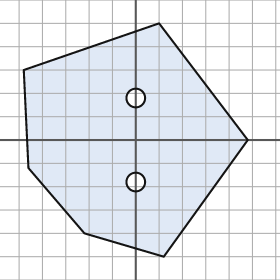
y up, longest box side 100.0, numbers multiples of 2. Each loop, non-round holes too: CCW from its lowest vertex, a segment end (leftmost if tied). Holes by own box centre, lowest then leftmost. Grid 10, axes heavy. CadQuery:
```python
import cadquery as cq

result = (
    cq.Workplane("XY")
    .moveTo(12.0, -50.0)
    .lineTo(48.0, 0.0)
    .lineTo(10.0, 50.0)
    .lineTo(-48.0, 30.0)
    .lineTo(-46.0, -12.0)
    .lineTo(-22.0, -40.0)
    .close()
    .moveTo(0.0, -18.0)
    .circle(4.0)
    .moveTo(0.0, 18.0)
    .circle(4.0)
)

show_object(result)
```